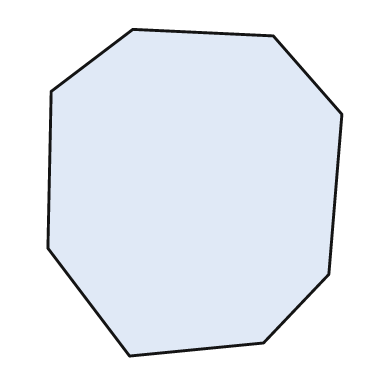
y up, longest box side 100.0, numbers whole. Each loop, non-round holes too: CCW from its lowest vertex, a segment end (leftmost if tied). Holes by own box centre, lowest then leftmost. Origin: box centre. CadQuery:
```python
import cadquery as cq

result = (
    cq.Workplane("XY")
    .moveTo(-20.0, -50.0)
    .lineTo(21.0, -46.0)
    .lineTo(41.0, -25.0)
    .lineTo(45.0, 24.0)
    .lineTo(24.0, 48.0)
    .lineTo(-19.0, 50.0)
    .lineTo(-44.0, 31.0)
    .lineTo(-45.0, -17.0)
    .close()
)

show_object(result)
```